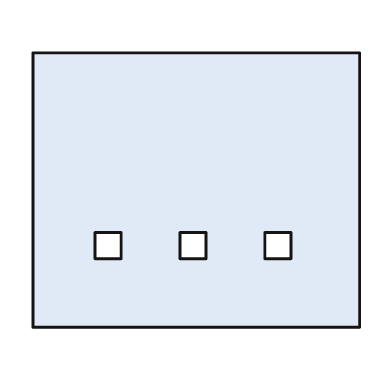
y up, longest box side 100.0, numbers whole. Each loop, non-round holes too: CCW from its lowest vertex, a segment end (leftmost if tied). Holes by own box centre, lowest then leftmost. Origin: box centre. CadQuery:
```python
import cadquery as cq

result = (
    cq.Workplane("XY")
    .moveTo(-50.0, -42.0)
    .lineTo(50.0, -42.0)
    .lineTo(50.0, 42.0)
    .lineTo(-50.0, 42.0)
    .close()
    .moveTo(-31.0, -21.0)
    .lineTo(-23.0, -21.0)
    .lineTo(-23.0, -13.0)
    .lineTo(-31.0, -13.0)
    .close()
    .moveTo(-5.0, -21.0)
    .lineTo(3.0, -21.0)
    .lineTo(3.0, -13.0)
    .lineTo(-5.0, -13.0)
    .close()
    .moveTo(21.0, -21.0)
    .lineTo(29.0, -21.0)
    .lineTo(29.0, -13.0)
    .lineTo(21.0, -13.0)
    .close()
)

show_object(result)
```